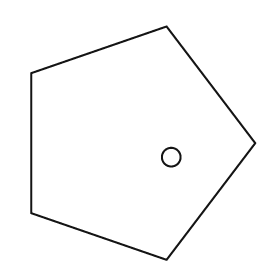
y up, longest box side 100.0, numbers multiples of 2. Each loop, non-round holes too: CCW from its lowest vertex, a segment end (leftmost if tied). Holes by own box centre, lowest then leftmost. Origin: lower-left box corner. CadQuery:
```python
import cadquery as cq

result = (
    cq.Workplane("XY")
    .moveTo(58.0, 0.0)
    .lineTo(96.0, 50.0)
    .lineTo(58.0, 100.0)
    .lineTo(0.0, 80.0)
    .lineTo(0.0, 20.0)
    .close()
    .moveTo(60.0, 44.0)
    .circle(4.0)
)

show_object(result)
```